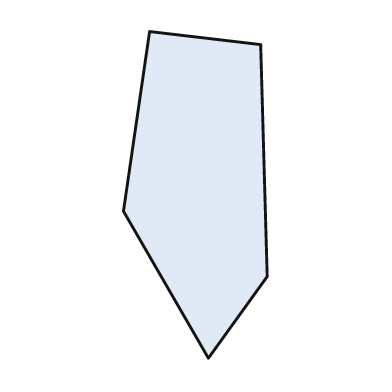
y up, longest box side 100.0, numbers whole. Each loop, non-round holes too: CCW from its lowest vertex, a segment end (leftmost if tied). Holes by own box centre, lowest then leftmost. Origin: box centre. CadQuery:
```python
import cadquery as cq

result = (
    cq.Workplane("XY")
    .moveTo(4.0, -50.0)
    .lineTo(22.0, -25.0)
    .lineTo(20.0, 46.0)
    .lineTo(-14.0, 50.0)
    .lineTo(-22.0, -5.0)
    .close()
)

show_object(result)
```